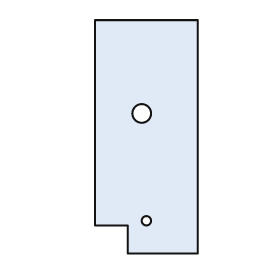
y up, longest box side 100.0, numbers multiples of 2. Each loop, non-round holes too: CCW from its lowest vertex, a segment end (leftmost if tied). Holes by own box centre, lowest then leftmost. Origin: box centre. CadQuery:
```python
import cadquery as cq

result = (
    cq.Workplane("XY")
    .moveTo(-8.0, -50.0)
    .lineTo(22.0, -50.0)
    .lineTo(22.0, 50.0)
    .lineTo(-22.0, 50.0)
    .lineTo(-22.0, -38.0)
    .lineTo(-8.0, -38.0)
    .close()
    .moveTo(0.0, -36.0)
    .circle(2.0)
    .moveTo(-2.0, 10.0)
    .circle(4.0)
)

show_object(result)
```